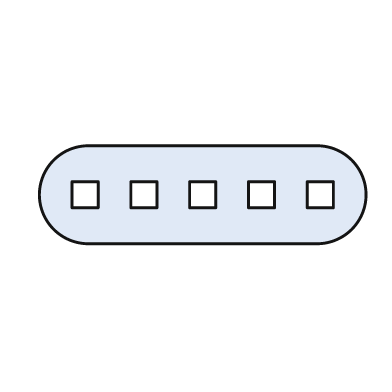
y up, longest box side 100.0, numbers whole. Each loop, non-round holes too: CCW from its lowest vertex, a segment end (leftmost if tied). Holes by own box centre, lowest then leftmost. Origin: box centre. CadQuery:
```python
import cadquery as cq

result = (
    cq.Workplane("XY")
    .moveTo(-35.0, -15.0)
    .lineTo(35.0, -15.0)
    .threePointArc((50.0, 0.0), (35.0, 15.0))
    .lineTo(-35.0, 15.0)
    .threePointArc((-50.0, 0.0), (-35.0, -15.0))
    .close()
    .moveTo(-40.0, -4.0)
    .lineTo(-32.0, -4.0)
    .lineTo(-32.0, 4.0)
    .lineTo(-40.0, 4.0)
    .close()
    .moveTo(-22.0, -4.0)
    .lineTo(-14.0, -4.0)
    .lineTo(-14.0, 4.0)
    .lineTo(-22.0, 4.0)
    .close()
    .moveTo(-4.0, -4.0)
    .lineTo(4.0, -4.0)
    .lineTo(4.0, 4.0)
    .lineTo(-4.0, 4.0)
    .close()
    .moveTo(14.0, -4.0)
    .lineTo(22.0, -4.0)
    .lineTo(22.0, 4.0)
    .lineTo(14.0, 4.0)
    .close()
    .moveTo(32.0, -4.0)
    .lineTo(40.0, -4.0)
    .lineTo(40.0, 4.0)
    .lineTo(32.0, 4.0)
    .close()
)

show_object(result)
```